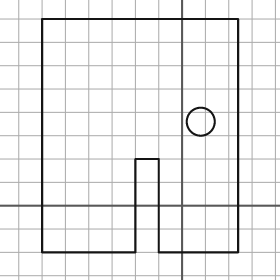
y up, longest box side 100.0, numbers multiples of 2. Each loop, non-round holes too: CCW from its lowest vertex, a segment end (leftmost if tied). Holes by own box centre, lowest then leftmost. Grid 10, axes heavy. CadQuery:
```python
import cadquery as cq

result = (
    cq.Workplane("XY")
    .moveTo(-60.0, -20.0)
    .lineTo(-20.0, -20.0)
    .lineTo(-20.0, 20.0)
    .lineTo(-10.0, 20.0)
    .lineTo(-10.0, -20.0)
    .lineTo(24.0, -20.0)
    .lineTo(24.0, 80.0)
    .lineTo(-60.0, 80.0)
    .close()
    .moveTo(8.0, 36.0)
    .circle(6.0)
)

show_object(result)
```